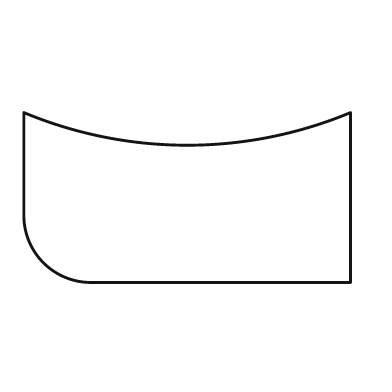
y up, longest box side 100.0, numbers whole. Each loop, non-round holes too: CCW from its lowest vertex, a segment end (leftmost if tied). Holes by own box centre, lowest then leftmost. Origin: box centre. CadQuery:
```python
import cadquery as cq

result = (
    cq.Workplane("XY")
    .moveTo(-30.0, -26.0)
    .lineTo(50.0, -26.0)
    .lineTo(50.0, 26.0)
    .threePointArc((0.0, 16.0), (-50.0, 26.0))
    .lineTo(-50.0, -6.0)
    .threePointArc((-44.0, -20.0), (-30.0, -26.0))
    .close()
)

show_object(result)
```